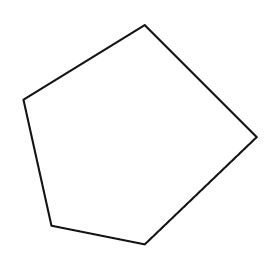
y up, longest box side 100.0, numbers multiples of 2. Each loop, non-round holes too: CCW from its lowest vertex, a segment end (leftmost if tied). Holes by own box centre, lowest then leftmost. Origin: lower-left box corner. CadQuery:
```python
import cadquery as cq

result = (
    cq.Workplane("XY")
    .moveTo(52.0, 0.0)
    .lineTo(100.0, 46.0)
    .lineTo(52.0, 94.0)
    .lineTo(0.0, 62.0)
    .lineTo(12.0, 8.0)
    .close()
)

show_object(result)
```